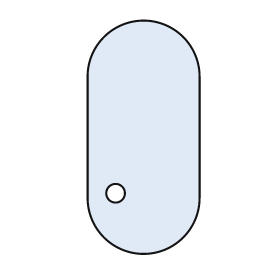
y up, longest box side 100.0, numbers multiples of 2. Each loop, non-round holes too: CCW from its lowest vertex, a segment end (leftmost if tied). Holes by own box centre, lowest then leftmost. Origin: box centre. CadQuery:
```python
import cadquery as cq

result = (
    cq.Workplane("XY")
    .moveTo(-24.0, -26.0)
    .threePointArc((0.0, -50.0), (24.0, -26.0))
    .lineTo(24.0, 26.0)
    .threePointArc((0.0, 50.0), (-24.0, 26.0))
    .close()
    .moveTo(-12.0, -24.0)
    .circle(4.0)
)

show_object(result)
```